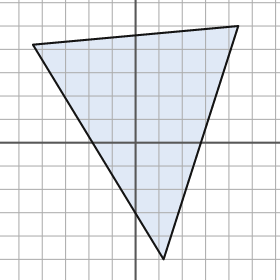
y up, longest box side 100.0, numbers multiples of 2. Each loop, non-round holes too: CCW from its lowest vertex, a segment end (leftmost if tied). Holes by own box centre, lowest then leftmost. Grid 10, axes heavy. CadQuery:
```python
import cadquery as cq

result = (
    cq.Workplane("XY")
    .moveTo(12.0, -50.0)
    .lineTo(44.0, 50.0)
    .lineTo(-44.0, 42.0)
    .close()
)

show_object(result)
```